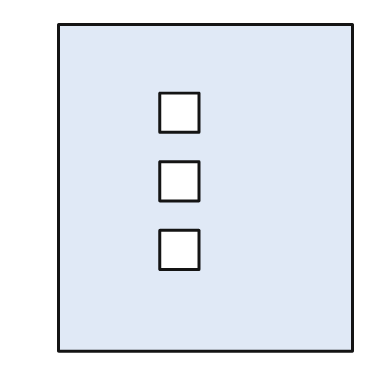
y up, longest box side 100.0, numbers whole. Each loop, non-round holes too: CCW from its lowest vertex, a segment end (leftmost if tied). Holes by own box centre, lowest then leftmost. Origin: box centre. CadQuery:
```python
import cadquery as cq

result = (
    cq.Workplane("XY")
    .moveTo(-45.0, -50.0)
    .lineTo(45.0, -50.0)
    .lineTo(45.0, 50.0)
    .lineTo(-45.0, 50.0)
    .close()
    .moveTo(-14.0, -25.0)
    .lineTo(-2.0, -25.0)
    .lineTo(-2.0, -13.0)
    .lineTo(-14.0, -13.0)
    .close()
    .moveTo(-14.0, -4.0)
    .lineTo(-2.0, -4.0)
    .lineTo(-2.0, 8.0)
    .lineTo(-14.0, 8.0)
    .close()
    .moveTo(-14.0, 17.0)
    .lineTo(-2.0, 17.0)
    .lineTo(-2.0, 29.0)
    .lineTo(-14.0, 29.0)
    .close()
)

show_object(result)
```